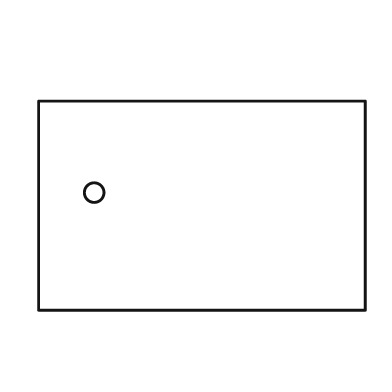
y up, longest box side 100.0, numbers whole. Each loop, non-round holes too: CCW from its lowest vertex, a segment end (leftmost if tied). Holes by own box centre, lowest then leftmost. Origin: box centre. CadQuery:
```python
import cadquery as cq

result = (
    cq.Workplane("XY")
    .moveTo(-50.0, -32.0)
    .lineTo(50.0, -32.0)
    .lineTo(50.0, 32.0)
    .lineTo(-50.0, 32.0)
    .close()
    .moveTo(-33.0, 4.0)
    .circle(3.0)
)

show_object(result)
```